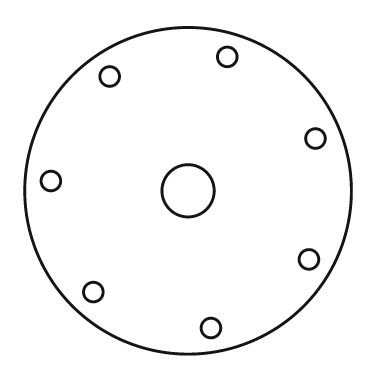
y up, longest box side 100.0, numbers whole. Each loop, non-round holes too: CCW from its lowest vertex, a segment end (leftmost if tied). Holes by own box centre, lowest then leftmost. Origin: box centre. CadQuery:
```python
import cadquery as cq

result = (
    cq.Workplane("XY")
    .moveTo(0.0, 0.0)
    .circle(50.0)
    .moveTo(7.0, -42.0)
    .circle(3.0)
    .moveTo(-29.0, -31.0)
    .circle(3.0)
    .moveTo(37.0, -21.0)
    .circle(3.0)
    .moveTo(0.0, 0.0)
    .circle(8.0)
    .moveTo(-42.0, 3.0)
    .circle(3.0)
    .moveTo(39.0, 16.0)
    .circle(3.0)
    .moveTo(-24.0, 35.0)
    .circle(3.0)
    .moveTo(12.0, 41.0)
    .circle(3.0)
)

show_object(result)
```